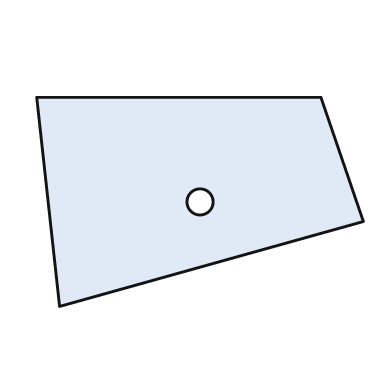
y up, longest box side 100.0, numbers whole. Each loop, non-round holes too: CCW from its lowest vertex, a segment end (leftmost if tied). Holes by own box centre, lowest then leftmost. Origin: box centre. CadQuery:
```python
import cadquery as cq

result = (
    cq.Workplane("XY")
    .moveTo(-43.0, -32.0)
    .lineTo(50.0, -6.0)
    .lineTo(37.0, 32.0)
    .lineTo(-50.0, 32.0)
    .close()
    .moveTo(0.0, 0.0)
    .circle(4.0)
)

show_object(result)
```